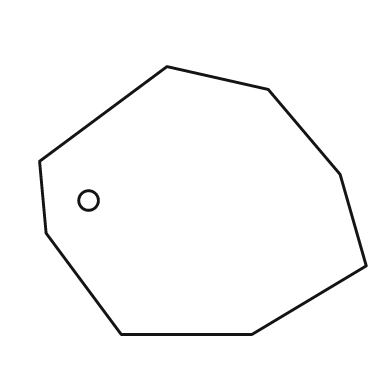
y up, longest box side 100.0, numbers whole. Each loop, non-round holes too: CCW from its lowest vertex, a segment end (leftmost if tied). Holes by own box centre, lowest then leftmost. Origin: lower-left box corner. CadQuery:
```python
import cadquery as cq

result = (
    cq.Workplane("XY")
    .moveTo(25.0, 0.0)
    .lineTo(65.0, 0.0)
    .lineTo(100.0, 21.0)
    .lineTo(92.0, 49.0)
    .lineTo(70.0, 75.0)
    .lineTo(39.0, 82.0)
    .lineTo(0.0, 53.0)
    .lineTo(2.0, 31.0)
    .close()
    .moveTo(15.0, 41.0)
    .circle(3.0)
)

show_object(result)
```